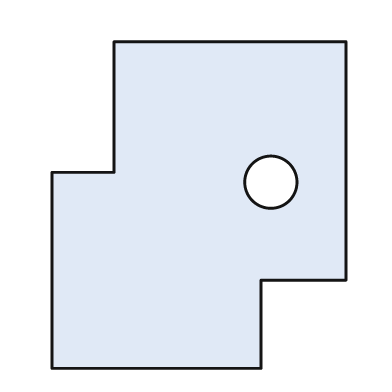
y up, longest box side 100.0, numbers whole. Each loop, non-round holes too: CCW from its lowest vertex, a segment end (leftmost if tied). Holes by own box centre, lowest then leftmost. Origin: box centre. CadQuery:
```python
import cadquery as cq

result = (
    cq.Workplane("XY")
    .moveTo(-45.0, -50.0)
    .lineTo(19.0, -50.0)
    .lineTo(19.0, -23.0)
    .lineTo(45.0, -23.0)
    .lineTo(45.0, 50.0)
    .lineTo(-26.0, 50.0)
    .lineTo(-26.0, 10.0)
    .lineTo(-45.0, 10.0)
    .close()
    .moveTo(22.0, 7.0)
    .circle(8.0)
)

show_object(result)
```